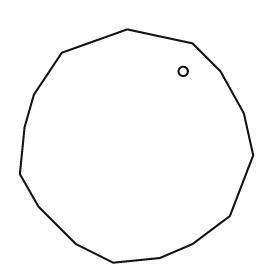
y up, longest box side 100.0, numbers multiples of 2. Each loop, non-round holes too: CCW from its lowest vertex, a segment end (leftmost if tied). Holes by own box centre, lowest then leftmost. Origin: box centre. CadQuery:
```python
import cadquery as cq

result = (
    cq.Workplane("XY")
    .moveTo(-10.0, -50.0)
    .lineTo(10.0, -48.0)
    .lineTo(24.0, -42.0)
    .lineTo(40.0, -30.0)
    .lineTo(50.0, -4.0)
    .lineTo(46.0, 14.0)
    .lineTo(36.0, 32.0)
    .lineTo(24.0, 44.0)
    .lineTo(-4.0, 50.0)
    .lineTo(-32.0, 40.0)
    .lineTo(-44.0, 22.0)
    .lineTo(-48.0, 8.0)
    .lineTo(-50.0, -12.0)
    .lineTo(-42.0, -26.0)
    .lineTo(-26.0, -42.0)
    .close()
    .moveTo(20.0, 32.0)
    .circle(2.0)
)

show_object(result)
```